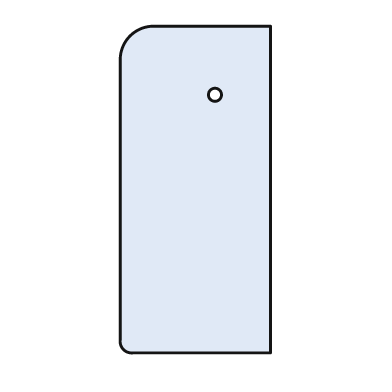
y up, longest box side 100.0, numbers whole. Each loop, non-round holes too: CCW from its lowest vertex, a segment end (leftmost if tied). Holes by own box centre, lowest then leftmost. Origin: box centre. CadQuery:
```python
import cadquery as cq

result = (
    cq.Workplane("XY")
    .moveTo(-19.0, -50.0)
    .lineTo(23.0, -50.0)
    .lineTo(23.0, 50.0)
    .lineTo(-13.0, 50.0)
    .threePointArc((-20.0, 47.0), (-23.0, 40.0))
    .lineTo(-23.0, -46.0)
    .threePointArc((-22.0, -49.0), (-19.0, -50.0))
    .close()
    .moveTo(6.0, 29.0)
    .circle(2.0)
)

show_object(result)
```